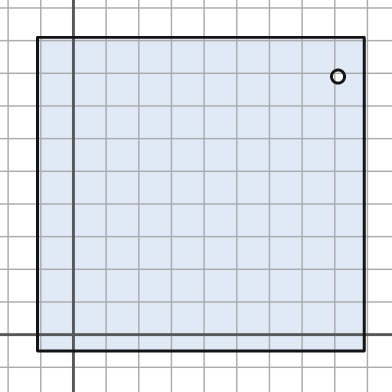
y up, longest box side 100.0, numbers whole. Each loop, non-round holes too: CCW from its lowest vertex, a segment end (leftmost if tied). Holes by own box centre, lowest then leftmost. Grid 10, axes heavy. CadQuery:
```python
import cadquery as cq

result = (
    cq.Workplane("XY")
    .moveTo(-11.0, -5.0)
    .lineTo(89.0, -5.0)
    .lineTo(89.0, 91.0)
    .lineTo(-11.0, 91.0)
    .close()
    .moveTo(81.0, 79.0)
    .circle(2.0)
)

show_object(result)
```